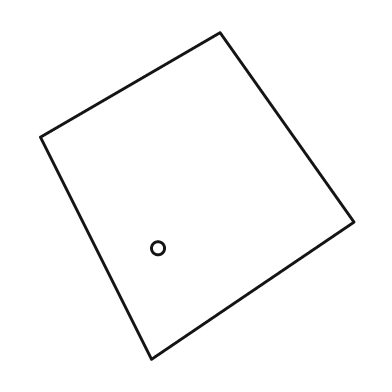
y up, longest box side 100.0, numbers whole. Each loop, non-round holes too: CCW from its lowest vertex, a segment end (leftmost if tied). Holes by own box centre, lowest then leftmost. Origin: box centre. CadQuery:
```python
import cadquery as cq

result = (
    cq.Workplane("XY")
    .moveTo(-14.0, -50.0)
    .lineTo(48.0, -8.0)
    .lineTo(7.0, 50.0)
    .lineTo(-48.0, 18.0)
    .close()
    .moveTo(-12.0, -16.0)
    .circle(2.0)
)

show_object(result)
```